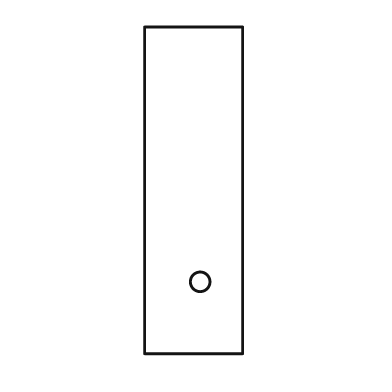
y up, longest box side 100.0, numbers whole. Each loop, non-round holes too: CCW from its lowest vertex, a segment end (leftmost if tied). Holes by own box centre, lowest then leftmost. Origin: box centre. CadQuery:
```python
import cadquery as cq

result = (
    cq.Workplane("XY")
    .moveTo(-15.0, -50.0)
    .lineTo(15.0, -50.0)
    .lineTo(15.0, 50.0)
    .lineTo(-15.0, 50.0)
    .close()
    .moveTo(2.0, -28.0)
    .circle(3.0)
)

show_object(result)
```